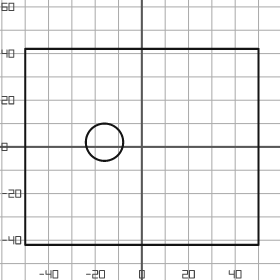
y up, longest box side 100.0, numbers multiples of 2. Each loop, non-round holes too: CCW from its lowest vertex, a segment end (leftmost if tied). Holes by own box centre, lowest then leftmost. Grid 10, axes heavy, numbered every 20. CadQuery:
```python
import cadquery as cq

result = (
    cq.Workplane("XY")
    .moveTo(-50.0, -42.0)
    .lineTo(50.0, -42.0)
    .lineTo(50.0, 42.0)
    .lineTo(-50.0, 42.0)
    .close()
    .moveTo(-16.0, 2.0)
    .circle(8.0)
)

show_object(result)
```